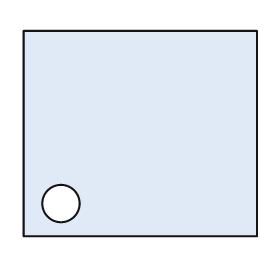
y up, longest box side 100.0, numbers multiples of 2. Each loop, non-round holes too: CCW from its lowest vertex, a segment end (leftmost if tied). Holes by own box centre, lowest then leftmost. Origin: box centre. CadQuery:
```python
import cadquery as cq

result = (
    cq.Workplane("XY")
    .moveTo(-50.0, -44.0)
    .lineTo(50.0, -44.0)
    .lineTo(50.0, 44.0)
    .lineTo(-50.0, 44.0)
    .close()
    .moveTo(-34.0, -30.0)
    .circle(8.0)
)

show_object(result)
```